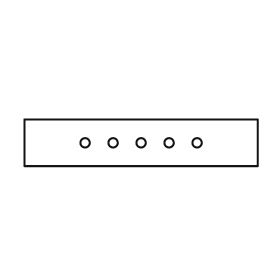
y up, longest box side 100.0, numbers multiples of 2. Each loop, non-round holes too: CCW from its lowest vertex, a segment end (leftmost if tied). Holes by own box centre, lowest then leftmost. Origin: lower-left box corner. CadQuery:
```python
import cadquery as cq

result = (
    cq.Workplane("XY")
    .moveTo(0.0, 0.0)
    .lineTo(100.0, 0.0)
    .lineTo(100.0, 20.0)
    .lineTo(0.0, 20.0)
    .close()
    .moveTo(26.0, 10.0)
    .circle(2.0)
    .moveTo(38.0, 10.0)
    .circle(2.0)
    .moveTo(50.0, 10.0)
    .circle(2.0)
    .moveTo(62.0, 10.0)
    .circle(2.0)
    .moveTo(74.0, 10.0)
    .circle(2.0)
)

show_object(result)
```